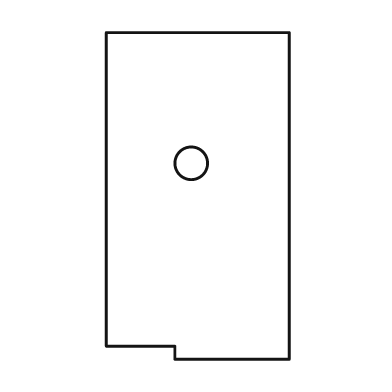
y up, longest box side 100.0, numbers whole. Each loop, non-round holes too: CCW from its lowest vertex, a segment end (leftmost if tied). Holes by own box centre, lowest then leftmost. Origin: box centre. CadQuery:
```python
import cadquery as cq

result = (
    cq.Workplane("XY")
    .moveTo(-7.0, -50.0)
    .lineTo(28.0, -50.0)
    .lineTo(28.0, 50.0)
    .lineTo(-28.0, 50.0)
    .lineTo(-28.0, -46.0)
    .lineTo(-7.0, -46.0)
    .close()
    .moveTo(-2.0, 10.0)
    .circle(5.0)
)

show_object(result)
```